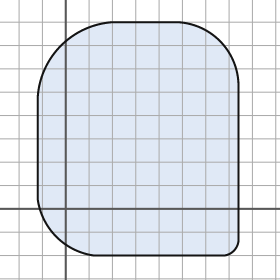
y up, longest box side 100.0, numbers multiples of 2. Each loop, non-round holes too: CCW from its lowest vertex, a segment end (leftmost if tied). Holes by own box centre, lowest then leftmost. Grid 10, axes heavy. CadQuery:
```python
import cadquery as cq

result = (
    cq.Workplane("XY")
    .moveTo(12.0, -20.0)
    .lineTo(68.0, -20.0)
    .threePointArc((72.0, -18.0), (74.0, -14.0))
    .lineTo(74.0, 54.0)
    .threePointArc((66.0, 72.0), (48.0, 80.0))
    .lineTo(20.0, 80.0)
    .threePointArc((-2.0, 70.0), (-12.0, 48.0))
    .lineTo(-12.0, 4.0)
    .threePointArc((-4.0, -12.0), (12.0, -20.0))
    .close()
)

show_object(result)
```